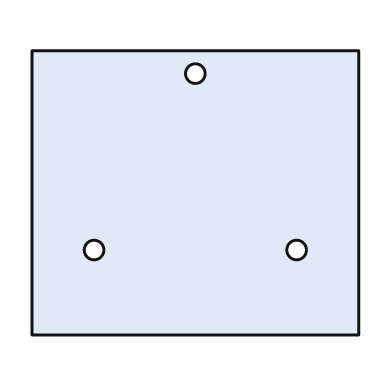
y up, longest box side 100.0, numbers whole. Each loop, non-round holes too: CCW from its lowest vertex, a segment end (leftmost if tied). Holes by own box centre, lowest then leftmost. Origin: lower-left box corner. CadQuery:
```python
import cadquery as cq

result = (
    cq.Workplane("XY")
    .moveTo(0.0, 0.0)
    .lineTo(100.0, 0.0)
    .lineTo(100.0, 87.0)
    .lineTo(0.0, 87.0)
    .close()
    .moveTo(19.0, 26.0)
    .circle(3.0)
    .moveTo(81.0, 26.0)
    .circle(3.0)
    .moveTo(50.0, 80.0)
    .circle(3.0)
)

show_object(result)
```